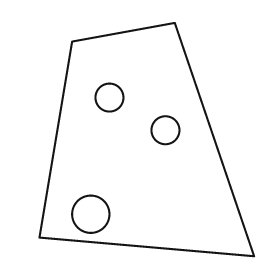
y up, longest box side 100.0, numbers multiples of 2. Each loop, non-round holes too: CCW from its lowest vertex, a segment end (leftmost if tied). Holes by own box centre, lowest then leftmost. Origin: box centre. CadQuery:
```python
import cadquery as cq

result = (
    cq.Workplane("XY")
    .moveTo(46.0, -50.0)
    .lineTo(12.0, 50.0)
    .lineTo(-32.0, 42.0)
    .lineTo(-46.0, -42.0)
    .close()
    .moveTo(-24.0, -32.0)
    .circle(8.0)
    .moveTo(8.0, 4.0)
    .circle(6.0)
    .moveTo(-16.0, 18.0)
    .circle(6.0)
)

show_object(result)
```